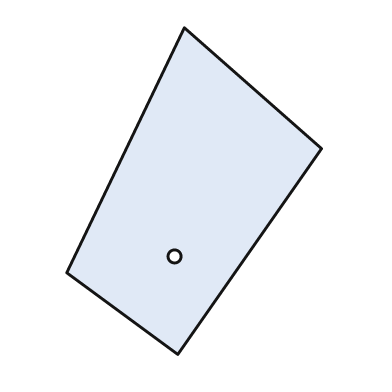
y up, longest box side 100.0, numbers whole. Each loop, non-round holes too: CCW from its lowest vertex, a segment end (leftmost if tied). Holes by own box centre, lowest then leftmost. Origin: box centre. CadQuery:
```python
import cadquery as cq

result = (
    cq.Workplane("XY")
    .moveTo(-5.0, -50.0)
    .lineTo(39.0, 13.0)
    .lineTo(-3.0, 50.0)
    .lineTo(-39.0, -25.0)
    .close()
    .moveTo(-6.0, -20.0)
    .circle(2.0)
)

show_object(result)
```